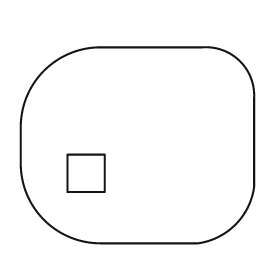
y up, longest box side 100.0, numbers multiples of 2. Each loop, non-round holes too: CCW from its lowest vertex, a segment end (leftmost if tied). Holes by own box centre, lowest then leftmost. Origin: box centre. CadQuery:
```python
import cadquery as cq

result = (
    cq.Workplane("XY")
    .moveTo(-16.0, -42.0)
    .lineTo(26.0, -42.0)
    .threePointArc((42.0, -34.0), (50.0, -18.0))
    .lineTo(50.0, 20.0)
    .threePointArc((44.0, 36.0), (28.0, 42.0))
    .lineTo(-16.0, 42.0)
    .threePointArc((-40.0, 32.0), (-50.0, 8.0))
    .lineTo(-50.0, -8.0)
    .threePointArc((-40.0, -32.0), (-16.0, -42.0))
    .close()
    .moveTo(-30.0, -20.0)
    .lineTo(-14.0, -20.0)
    .lineTo(-14.0, -4.0)
    .lineTo(-30.0, -4.0)
    .close()
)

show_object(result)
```